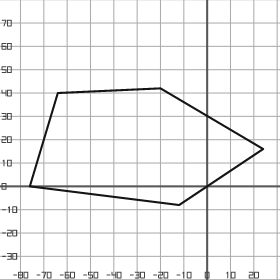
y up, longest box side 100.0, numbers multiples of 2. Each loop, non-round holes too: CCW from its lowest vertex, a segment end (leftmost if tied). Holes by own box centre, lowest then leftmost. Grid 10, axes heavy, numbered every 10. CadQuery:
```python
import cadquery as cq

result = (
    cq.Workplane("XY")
    .moveTo(-12.0, -8.0)
    .lineTo(24.0, 16.0)
    .lineTo(-20.0, 42.0)
    .lineTo(-64.0, 40.0)
    .lineTo(-76.0, 0.0)
    .close()
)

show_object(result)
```